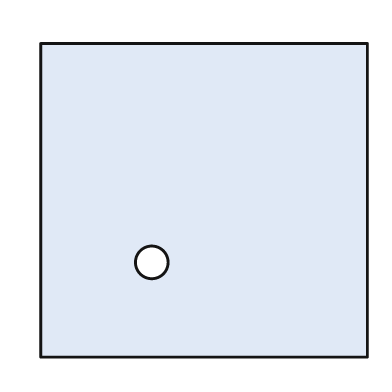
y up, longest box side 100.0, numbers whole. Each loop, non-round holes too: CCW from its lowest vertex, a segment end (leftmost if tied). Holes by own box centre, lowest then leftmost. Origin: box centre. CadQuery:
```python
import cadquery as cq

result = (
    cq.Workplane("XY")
    .moveTo(-50.0, -48.0)
    .lineTo(50.0, -48.0)
    .lineTo(50.0, 48.0)
    .lineTo(-50.0, 48.0)
    .close()
    .moveTo(-16.0, -19.0)
    .circle(5.0)
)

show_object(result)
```